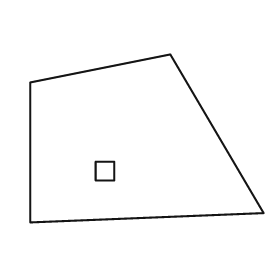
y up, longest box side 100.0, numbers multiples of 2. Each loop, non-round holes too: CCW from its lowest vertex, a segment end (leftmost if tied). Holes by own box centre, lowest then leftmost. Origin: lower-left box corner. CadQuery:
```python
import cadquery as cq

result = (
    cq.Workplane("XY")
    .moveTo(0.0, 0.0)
    .lineTo(100.0, 4.0)
    .lineTo(60.0, 72.0)
    .lineTo(0.0, 60.0)
    .close()
    .moveTo(28.0, 18.0)
    .lineTo(36.0, 18.0)
    .lineTo(36.0, 26.0)
    .lineTo(28.0, 26.0)
    .close()
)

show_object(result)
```